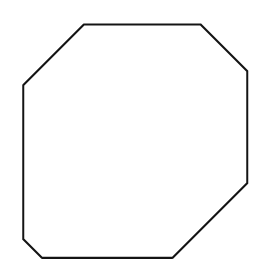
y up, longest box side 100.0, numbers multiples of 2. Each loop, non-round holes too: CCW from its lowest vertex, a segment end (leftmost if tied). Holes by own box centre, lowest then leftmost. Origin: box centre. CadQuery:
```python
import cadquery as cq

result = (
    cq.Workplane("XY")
    .moveTo(-40.0, -50.0)
    .lineTo(16.0, -50.0)
    .lineTo(48.0, -18.0)
    .lineTo(48.0, 30.0)
    .lineTo(28.0, 50.0)
    .lineTo(-22.0, 50.0)
    .lineTo(-48.0, 24.0)
    .lineTo(-48.0, -42.0)
    .close()
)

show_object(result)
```